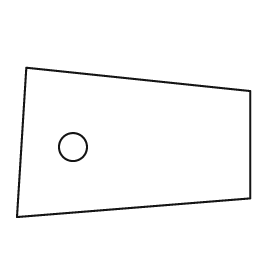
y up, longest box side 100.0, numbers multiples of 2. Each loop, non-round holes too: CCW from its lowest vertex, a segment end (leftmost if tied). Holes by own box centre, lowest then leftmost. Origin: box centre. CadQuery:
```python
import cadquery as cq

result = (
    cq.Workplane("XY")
    .moveTo(-50.0, -32.0)
    .lineTo(50.0, -24.0)
    .lineTo(50.0, 22.0)
    .lineTo(-46.0, 32.0)
    .close()
    .moveTo(-26.0, -2.0)
    .circle(6.0)
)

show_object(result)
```